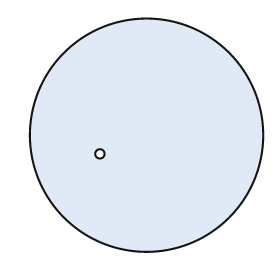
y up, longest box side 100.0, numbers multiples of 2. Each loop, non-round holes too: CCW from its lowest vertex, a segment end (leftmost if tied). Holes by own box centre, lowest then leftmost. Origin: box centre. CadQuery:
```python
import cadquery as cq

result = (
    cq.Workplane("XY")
    .moveTo(0.0, 0.0)
    .circle(50.0)
    .moveTo(-20.0, -8.0)
    .circle(2.0)
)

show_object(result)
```